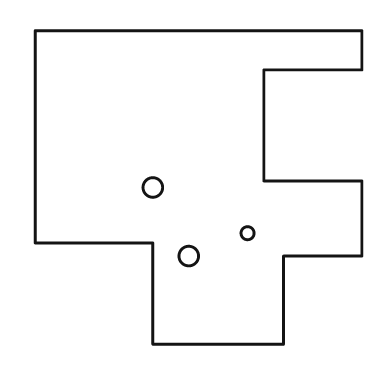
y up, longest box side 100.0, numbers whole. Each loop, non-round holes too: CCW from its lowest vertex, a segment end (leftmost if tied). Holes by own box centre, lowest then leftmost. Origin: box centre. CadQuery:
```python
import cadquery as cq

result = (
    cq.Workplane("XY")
    .moveTo(-14.0, -48.0)
    .lineTo(26.0, -48.0)
    .lineTo(26.0, -21.0)
    .lineTo(50.0, -21.0)
    .lineTo(50.0, 2.0)
    .lineTo(20.0, 2.0)
    .lineTo(20.0, 36.0)
    .lineTo(50.0, 36.0)
    .lineTo(50.0, 48.0)
    .lineTo(-50.0, 48.0)
    .lineTo(-50.0, -17.0)
    .lineTo(-14.0, -17.0)
    .close()
    .moveTo(-3.0, -21.0)
    .circle(3.0)
    .moveTo(15.0, -14.0)
    .circle(2.0)
    .moveTo(-14.0, 0.0)
    .circle(3.0)
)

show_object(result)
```